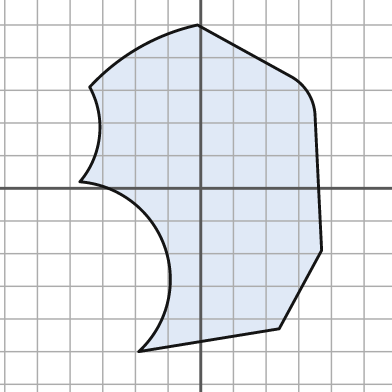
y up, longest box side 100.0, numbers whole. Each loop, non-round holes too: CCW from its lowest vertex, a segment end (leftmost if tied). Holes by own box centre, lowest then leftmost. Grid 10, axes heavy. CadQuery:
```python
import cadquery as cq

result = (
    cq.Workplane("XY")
    .moveTo(-19.0, -50.0)
    .lineTo(24.0, -43.0)
    .lineTo(37.0, -19.0)
    .lineTo(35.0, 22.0)
    .threePointArc((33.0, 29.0), (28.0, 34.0))
    .lineTo(-1.0, 50.0)
    .threePointArc((-19.0, 43.0), (-34.0, 31.0))
    .threePointArc((-31.0, 16.0), (-37.0, 2.0))
    .threePointArc((-11.0, -18.0), (-19.0, -50.0))
    .close()
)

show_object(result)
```